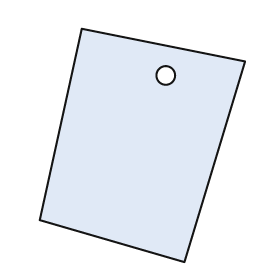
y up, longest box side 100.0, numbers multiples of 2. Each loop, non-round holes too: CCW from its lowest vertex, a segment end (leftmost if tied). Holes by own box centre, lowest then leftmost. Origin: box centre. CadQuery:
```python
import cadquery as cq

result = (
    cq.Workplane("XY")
    .moveTo(18.0, -50.0)
    .lineTo(44.0, 36.0)
    .lineTo(-26.0, 50.0)
    .lineTo(-44.0, -32.0)
    .close()
    .moveTo(10.0, 30.0)
    .circle(4.0)
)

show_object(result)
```